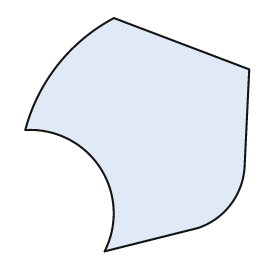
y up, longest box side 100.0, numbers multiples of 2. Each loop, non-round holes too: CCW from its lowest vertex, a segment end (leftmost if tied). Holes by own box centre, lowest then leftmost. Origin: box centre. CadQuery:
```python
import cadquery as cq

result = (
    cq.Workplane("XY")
    .moveTo(-14.0, -50.0)
    .lineTo(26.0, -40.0)
    .threePointArc((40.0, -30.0), (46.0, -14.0))
    .lineTo(48.0, 28.0)
    .lineTo(-10.0, 50.0)
    .threePointArc((-34.0, 30.0), (-48.0, 2.0))
    .threePointArc((-16.0, -14.0), (-14.0, -50.0))
    .close()
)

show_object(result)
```